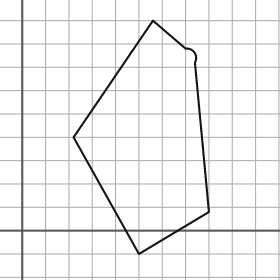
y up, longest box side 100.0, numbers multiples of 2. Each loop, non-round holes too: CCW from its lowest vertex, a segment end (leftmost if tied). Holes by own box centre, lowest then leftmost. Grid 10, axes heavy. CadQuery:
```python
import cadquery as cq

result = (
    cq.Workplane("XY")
    .moveTo(50.0, -10.0)
    .lineTo(80.0, 8.0)
    .lineTo(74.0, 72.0)
    .threePointArc((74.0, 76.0), (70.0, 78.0))
    .lineTo(56.0, 90.0)
    .lineTo(22.0, 40.0)
    .close()
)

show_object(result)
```